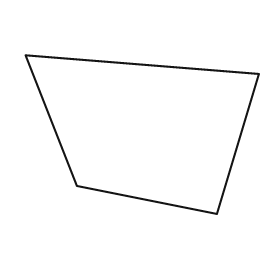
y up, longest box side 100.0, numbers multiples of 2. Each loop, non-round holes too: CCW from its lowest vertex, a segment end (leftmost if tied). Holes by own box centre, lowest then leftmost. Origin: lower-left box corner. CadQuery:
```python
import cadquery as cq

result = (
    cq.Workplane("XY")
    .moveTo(82.0, 0.0)
    .lineTo(100.0, 60.0)
    .lineTo(0.0, 68.0)
    .lineTo(22.0, 12.0)
    .close()
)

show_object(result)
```